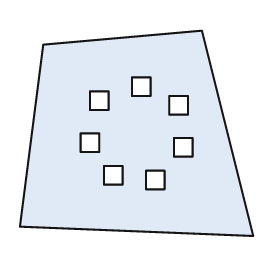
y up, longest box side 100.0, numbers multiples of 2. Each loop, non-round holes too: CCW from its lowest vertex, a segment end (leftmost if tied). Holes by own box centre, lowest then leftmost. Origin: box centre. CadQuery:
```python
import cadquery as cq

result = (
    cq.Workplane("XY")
    .moveTo(50.0, -44.0)
    .lineTo(28.0, 44.0)
    .lineTo(-40.0, 38.0)
    .lineTo(-50.0, -40.0)
    .close()
    .moveTo(4.0, -24.0)
    .lineTo(12.0, -24.0)
    .lineTo(12.0, -16.0)
    .lineTo(4.0, -16.0)
    .close()
    .moveTo(-14.0, -22.0)
    .lineTo(-6.0, -22.0)
    .lineTo(-6.0, -14.0)
    .lineTo(-14.0, -14.0)
    .close()
    .moveTo(16.0, -10.0)
    .lineTo(24.0, -10.0)
    .lineTo(24.0, -2.0)
    .lineTo(16.0, -2.0)
    .close()
    .moveTo(-24.0, -8.0)
    .lineTo(-16.0, -8.0)
    .lineTo(-16.0, 0.0)
    .lineTo(-24.0, 0.0)
    .close()
    .moveTo(14.0, 8.0)
    .lineTo(22.0, 8.0)
    .lineTo(22.0, 16.0)
    .lineTo(14.0, 16.0)
    .close()
    .moveTo(-20.0, 10.0)
    .lineTo(-12.0, 10.0)
    .lineTo(-12.0, 18.0)
    .lineTo(-20.0, 18.0)
    .close()
    .moveTo(-2.0, 16.0)
    .lineTo(6.0, 16.0)
    .lineTo(6.0, 24.0)
    .lineTo(-2.0, 24.0)
    .close()
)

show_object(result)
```